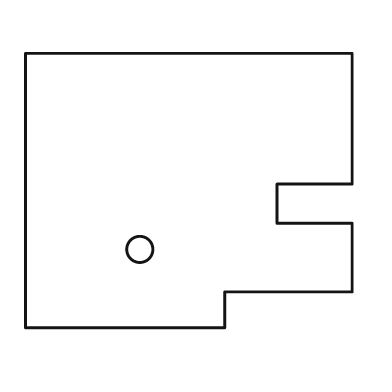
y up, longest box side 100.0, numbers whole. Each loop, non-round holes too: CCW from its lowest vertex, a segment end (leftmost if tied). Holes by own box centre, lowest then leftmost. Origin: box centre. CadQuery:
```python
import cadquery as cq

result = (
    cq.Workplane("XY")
    .moveTo(-50.0, -42.0)
    .lineTo(11.0, -42.0)
    .lineTo(11.0, -31.0)
    .lineTo(50.0, -31.0)
    .lineTo(50.0, -10.0)
    .lineTo(27.0, -10.0)
    .lineTo(27.0, 2.0)
    .lineTo(50.0, 2.0)
    .lineTo(50.0, 42.0)
    .lineTo(-50.0, 42.0)
    .close()
    .moveTo(-15.0, -18.0)
    .circle(4.0)
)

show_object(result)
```